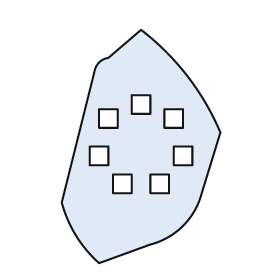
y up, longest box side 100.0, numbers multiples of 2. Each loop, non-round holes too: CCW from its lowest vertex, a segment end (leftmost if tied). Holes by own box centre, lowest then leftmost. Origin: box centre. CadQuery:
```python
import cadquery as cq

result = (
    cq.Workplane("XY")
    .moveTo(-18.0, -50.0)
    .lineTo(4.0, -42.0)
    .threePointArc((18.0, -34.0), (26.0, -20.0))
    .lineTo(34.0, 6.0)
    .threePointArc((20.0, 30.0), (0.0, 50.0))
    .lineTo(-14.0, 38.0)
    .threePointArc((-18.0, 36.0), (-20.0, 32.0))
    .lineTo(-34.0, -24.0)
    .threePointArc((-28.0, -38.0), (-18.0, -50.0))
    .close()
    .moveTo(-12.0, -20.0)
    .lineTo(-4.0, -20.0)
    .lineTo(-4.0, -12.0)
    .lineTo(-12.0, -12.0)
    .close()
    .moveTo(4.0, -20.0)
    .lineTo(12.0, -20.0)
    .lineTo(12.0, -12.0)
    .lineTo(4.0, -12.0)
    .close()
    .moveTo(-22.0, -8.0)
    .lineTo(-14.0, -8.0)
    .lineTo(-14.0, 0.0)
    .lineTo(-22.0, 0.0)
    .close()
    .moveTo(14.0, -8.0)
    .lineTo(22.0, -8.0)
    .lineTo(22.0, 0.0)
    .lineTo(14.0, 0.0)
    .close()
    .moveTo(-18.0, 8.0)
    .lineTo(-10.0, 8.0)
    .lineTo(-10.0, 16.0)
    .lineTo(-18.0, 16.0)
    .close()
    .moveTo(10.0, 8.0)
    .lineTo(18.0, 8.0)
    .lineTo(18.0, 16.0)
    .lineTo(10.0, 16.0)
    .close()
    .moveTo(-4.0, 14.0)
    .lineTo(4.0, 14.0)
    .lineTo(4.0, 22.0)
    .lineTo(-4.0, 22.0)
    .close()
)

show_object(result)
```